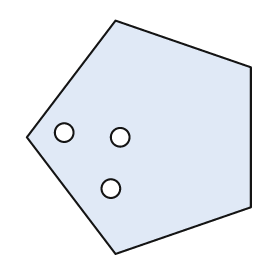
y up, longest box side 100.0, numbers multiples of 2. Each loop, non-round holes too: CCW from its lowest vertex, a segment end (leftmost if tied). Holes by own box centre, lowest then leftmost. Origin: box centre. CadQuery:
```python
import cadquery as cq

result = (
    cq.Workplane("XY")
    .moveTo(-10.0, -50.0)
    .lineTo(48.0, -30.0)
    .lineTo(48.0, 30.0)
    .lineTo(-10.0, 50.0)
    .lineTo(-48.0, 0.0)
    .close()
    .moveTo(-12.0, -22.0)
    .circle(4.0)
    .moveTo(-8.0, 0.0)
    .circle(4.0)
    .moveTo(-32.0, 2.0)
    .circle(4.0)
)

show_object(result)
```